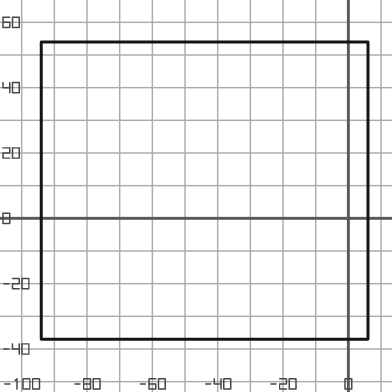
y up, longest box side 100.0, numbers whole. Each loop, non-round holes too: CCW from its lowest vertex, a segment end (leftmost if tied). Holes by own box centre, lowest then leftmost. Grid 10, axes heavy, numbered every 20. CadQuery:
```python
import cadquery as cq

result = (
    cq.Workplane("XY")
    .moveTo(-94.0, -37.0)
    .lineTo(6.0, -37.0)
    .lineTo(6.0, 54.0)
    .lineTo(-94.0, 54.0)
    .close()
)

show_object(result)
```